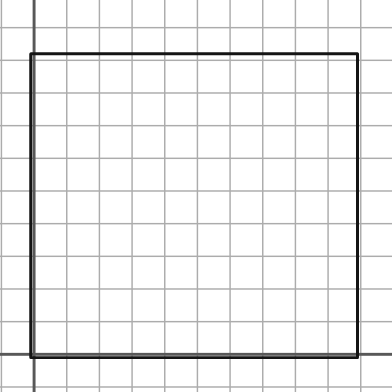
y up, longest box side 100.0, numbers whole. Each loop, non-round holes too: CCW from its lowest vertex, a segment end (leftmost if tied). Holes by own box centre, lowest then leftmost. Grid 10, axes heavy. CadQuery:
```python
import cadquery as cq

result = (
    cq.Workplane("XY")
    .moveTo(-1.0, -1.0)
    .lineTo(99.0, -1.0)
    .lineTo(99.0, 92.0)
    .lineTo(-1.0, 92.0)
    .close()
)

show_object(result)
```